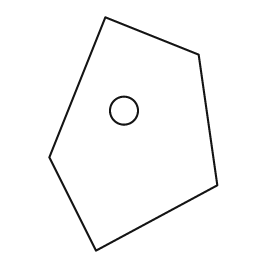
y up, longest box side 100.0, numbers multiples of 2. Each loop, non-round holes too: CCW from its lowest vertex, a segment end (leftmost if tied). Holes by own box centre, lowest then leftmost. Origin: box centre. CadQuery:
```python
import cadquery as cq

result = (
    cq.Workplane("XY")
    .moveTo(-16.0, -50.0)
    .lineTo(36.0, -22.0)
    .lineTo(28.0, 34.0)
    .lineTo(-12.0, 50.0)
    .lineTo(-36.0, -10.0)
    .close()
    .moveTo(-4.0, 10.0)
    .circle(6.0)
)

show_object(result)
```